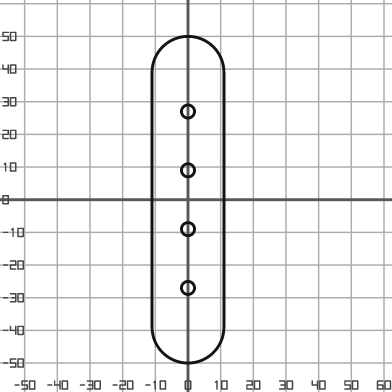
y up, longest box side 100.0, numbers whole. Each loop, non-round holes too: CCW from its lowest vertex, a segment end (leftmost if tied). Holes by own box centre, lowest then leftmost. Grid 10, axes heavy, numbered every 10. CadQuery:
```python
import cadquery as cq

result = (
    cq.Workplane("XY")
    .moveTo(-11.0, -39.0)
    .threePointArc((0.0, -50.0), (11.0, -39.0))
    .lineTo(11.0, 39.0)
    .threePointArc((0.0, 50.0), (-11.0, 39.0))
    .close()
    .moveTo(0.0, -27.0)
    .circle(2.0)
    .moveTo(0.0, -9.0)
    .circle(2.0)
    .moveTo(0.0, 9.0)
    .circle(2.0)
    .moveTo(0.0, 27.0)
    .circle(2.0)
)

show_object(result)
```